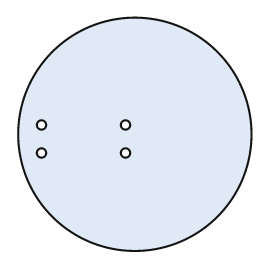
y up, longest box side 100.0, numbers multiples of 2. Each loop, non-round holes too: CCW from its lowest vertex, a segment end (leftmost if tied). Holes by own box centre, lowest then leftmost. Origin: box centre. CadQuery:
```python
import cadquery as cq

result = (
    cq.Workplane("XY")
    .moveTo(0.0, 0.0)
    .circle(50.0)
    .moveTo(-40.0, -8.0)
    .circle(2.0)
    .moveTo(-4.0, -8.0)
    .circle(2.0)
    .moveTo(-40.0, 4.0)
    .circle(2.0)
    .moveTo(-4.0, 4.0)
    .circle(2.0)
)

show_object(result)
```